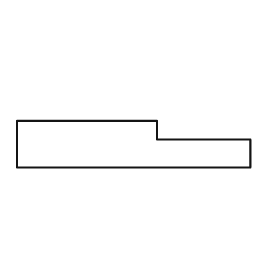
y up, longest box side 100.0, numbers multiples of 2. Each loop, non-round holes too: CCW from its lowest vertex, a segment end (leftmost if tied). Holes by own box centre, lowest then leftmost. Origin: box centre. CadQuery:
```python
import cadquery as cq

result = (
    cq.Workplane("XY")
    .moveTo(-50.0, -10.0)
    .lineTo(50.0, -10.0)
    .lineTo(50.0, 2.0)
    .lineTo(10.0, 2.0)
    .lineTo(10.0, 10.0)
    .lineTo(-50.0, 10.0)
    .close()
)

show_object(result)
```